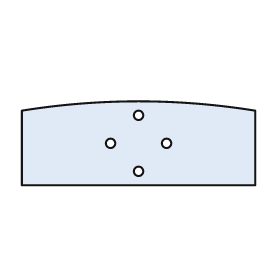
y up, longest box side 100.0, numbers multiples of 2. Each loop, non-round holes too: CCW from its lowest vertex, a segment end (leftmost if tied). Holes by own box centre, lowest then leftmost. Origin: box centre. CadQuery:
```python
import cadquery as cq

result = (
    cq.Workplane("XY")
    .moveTo(-50.0, -18.0)
    .lineTo(50.0, -18.0)
    .lineTo(50.0, 14.0)
    .threePointArc((0.0, 18.0), (-50.0, 14.0))
    .close()
    .moveTo(0.0, -12.0)
    .circle(2.0)
    .moveTo(-12.0, 0.0)
    .circle(2.0)
    .moveTo(12.0, 0.0)
    .circle(2.0)
    .moveTo(0.0, 12.0)
    .circle(2.0)
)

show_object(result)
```